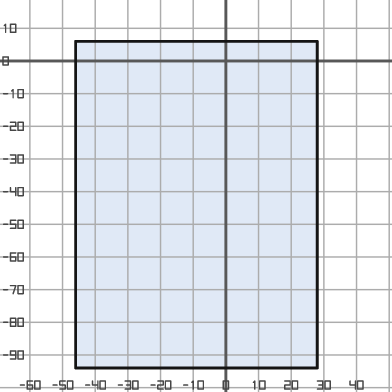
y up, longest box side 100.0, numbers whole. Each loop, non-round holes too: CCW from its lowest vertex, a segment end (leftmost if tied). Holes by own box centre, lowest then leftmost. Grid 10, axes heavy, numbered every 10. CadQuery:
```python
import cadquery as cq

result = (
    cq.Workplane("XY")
    .moveTo(-46.0, -94.0)
    .lineTo(28.0, -94.0)
    .lineTo(28.0, 6.0)
    .lineTo(-46.0, 6.0)
    .close()
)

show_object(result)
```